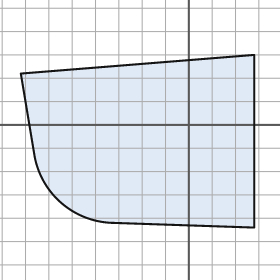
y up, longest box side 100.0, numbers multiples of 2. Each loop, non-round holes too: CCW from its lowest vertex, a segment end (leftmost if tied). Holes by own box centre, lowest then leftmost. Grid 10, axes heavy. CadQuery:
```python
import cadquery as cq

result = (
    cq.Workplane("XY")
    .moveTo(28.0, -44.0)
    .lineTo(28.0, 30.0)
    .lineTo(-72.0, 22.0)
    .lineTo(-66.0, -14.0)
    .threePointArc((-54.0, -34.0), (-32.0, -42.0))
    .close()
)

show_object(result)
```